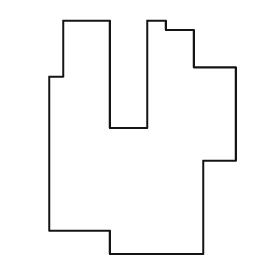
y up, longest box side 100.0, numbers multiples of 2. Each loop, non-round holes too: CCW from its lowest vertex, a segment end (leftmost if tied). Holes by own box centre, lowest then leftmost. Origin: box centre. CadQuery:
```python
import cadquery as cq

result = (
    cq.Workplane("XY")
    .moveTo(-14.0, -50.0)
    .lineTo(26.0, -50.0)
    .lineTo(26.0, -10.0)
    .lineTo(40.0, -10.0)
    .lineTo(40.0, 30.0)
    .lineTo(22.0, 30.0)
    .lineTo(22.0, 46.0)
    .lineTo(10.0, 46.0)
    .lineTo(10.0, 50.0)
    .lineTo(2.0, 50.0)
    .lineTo(2.0, 4.0)
    .lineTo(-14.0, 4.0)
    .lineTo(-14.0, 50.0)
    .lineTo(-34.0, 50.0)
    .lineTo(-34.0, 26.0)
    .lineTo(-40.0, 26.0)
    .lineTo(-40.0, -40.0)
    .lineTo(-14.0, -40.0)
    .close()
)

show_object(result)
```